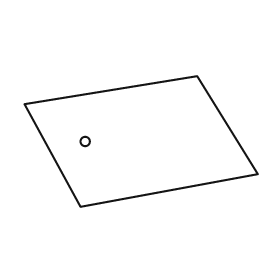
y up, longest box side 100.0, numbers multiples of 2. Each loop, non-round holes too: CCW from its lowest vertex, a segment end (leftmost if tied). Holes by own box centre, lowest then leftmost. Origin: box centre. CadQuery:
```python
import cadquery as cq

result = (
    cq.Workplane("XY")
    .moveTo(-26.0, -28.0)
    .lineTo(50.0, -14.0)
    .lineTo(24.0, 28.0)
    .lineTo(-50.0, 16.0)
    .close()
    .moveTo(-24.0, 0.0)
    .circle(2.0)
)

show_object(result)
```